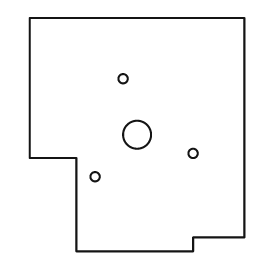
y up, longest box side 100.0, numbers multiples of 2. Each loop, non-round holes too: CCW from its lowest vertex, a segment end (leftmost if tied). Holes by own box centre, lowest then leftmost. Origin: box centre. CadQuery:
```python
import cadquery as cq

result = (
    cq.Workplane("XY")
    .moveTo(-26.0, -50.0)
    .lineTo(24.0, -50.0)
    .lineTo(24.0, -44.0)
    .lineTo(46.0, -44.0)
    .lineTo(46.0, 50.0)
    .lineTo(-46.0, 50.0)
    .lineTo(-46.0, -10.0)
    .lineTo(-26.0, -10.0)
    .close()
    .moveTo(-18.0, -18.0)
    .circle(2.0)
    .moveTo(24.0, -8.0)
    .circle(2.0)
    .moveTo(0.0, 0.0)
    .circle(6.0)
    .moveTo(-6.0, 24.0)
    .circle(2.0)
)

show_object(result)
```